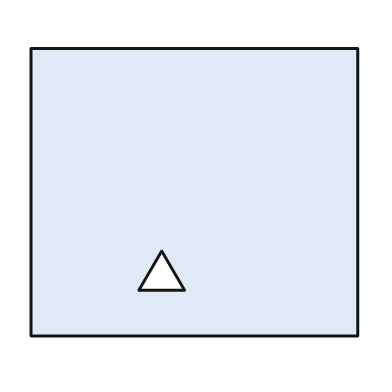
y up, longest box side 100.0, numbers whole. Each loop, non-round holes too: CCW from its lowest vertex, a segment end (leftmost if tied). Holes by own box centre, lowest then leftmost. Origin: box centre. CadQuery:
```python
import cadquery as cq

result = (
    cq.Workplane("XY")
    .moveTo(-50.0, -44.0)
    .lineTo(50.0, -44.0)
    .lineTo(50.0, 44.0)
    .lineTo(-50.0, 44.0)
    .close()
    .moveTo(-17.0, -30.0)
    .lineTo(-3.0, -30.0)
    .lineTo(-10.0, -18.0)
    .close()
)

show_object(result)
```